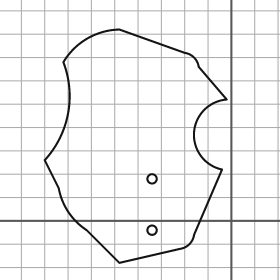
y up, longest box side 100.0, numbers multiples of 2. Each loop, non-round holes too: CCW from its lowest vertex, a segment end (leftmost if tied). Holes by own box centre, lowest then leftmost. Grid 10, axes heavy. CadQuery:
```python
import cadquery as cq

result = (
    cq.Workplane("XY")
    .moveTo(-48.0, -18.0)
    .lineTo(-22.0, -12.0)
    .threePointArc((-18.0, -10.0), (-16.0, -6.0))
    .lineTo(-4.0, 22.0)
    .threePointArc((-16.0, 38.0), (-2.0, 52.0))
    .lineTo(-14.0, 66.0)
    .threePointArc((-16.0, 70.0), (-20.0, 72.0))
    .lineTo(-48.0, 82.0)
    .threePointArc((-62.0, 78.0), (-72.0, 68.0))
    .threePointArc((-70.0, 46.0), (-80.0, 26.0))
    .lineTo(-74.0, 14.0)
    .threePointArc((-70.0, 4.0), (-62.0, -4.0))
    .close()
    .moveTo(-34.0, -4.0)
    .circle(2.0)
    .moveTo(-34.0, 18.0)
    .circle(2.0)
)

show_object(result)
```